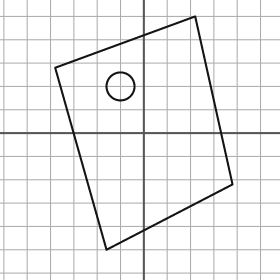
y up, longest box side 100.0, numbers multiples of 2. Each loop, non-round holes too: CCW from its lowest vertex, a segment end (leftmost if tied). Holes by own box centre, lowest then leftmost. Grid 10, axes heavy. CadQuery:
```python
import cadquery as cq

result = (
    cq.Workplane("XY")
    .moveTo(-16.0, -50.0)
    .lineTo(38.0, -22.0)
    .lineTo(22.0, 50.0)
    .lineTo(-38.0, 28.0)
    .close()
    .moveTo(-10.0, 20.0)
    .circle(6.0)
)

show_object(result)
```